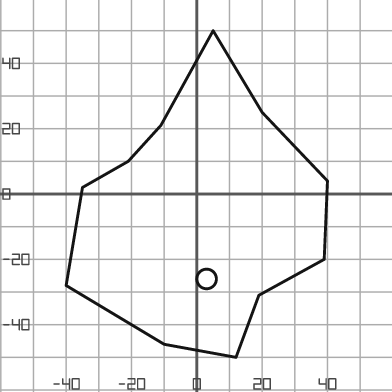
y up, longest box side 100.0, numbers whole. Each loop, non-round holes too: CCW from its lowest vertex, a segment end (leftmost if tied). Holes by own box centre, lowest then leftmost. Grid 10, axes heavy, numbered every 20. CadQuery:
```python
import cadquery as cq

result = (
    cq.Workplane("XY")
    .moveTo(12.0, -50.0)
    .lineTo(19.0, -31.0)
    .lineTo(39.0, -20.0)
    .lineTo(40.0, 4.0)
    .lineTo(20.0, 25.0)
    .lineTo(5.0, 50.0)
    .lineTo(-11.0, 21.0)
    .lineTo(-21.0, 10.0)
    .lineTo(-35.0, 2.0)
    .lineTo(-40.0, -28.0)
    .lineTo(-10.0, -46.0)
    .close()
    .moveTo(3.0, -26.0)
    .circle(3.0)
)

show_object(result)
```